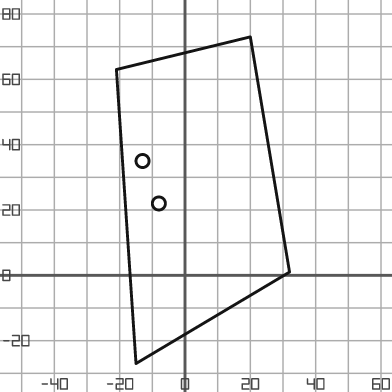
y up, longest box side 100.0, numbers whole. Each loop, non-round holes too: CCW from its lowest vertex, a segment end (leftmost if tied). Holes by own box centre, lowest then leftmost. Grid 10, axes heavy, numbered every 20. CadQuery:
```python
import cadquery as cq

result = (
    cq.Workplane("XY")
    .moveTo(-15.0, -27.0)
    .lineTo(32.0, 1.0)
    .lineTo(20.0, 73.0)
    .lineTo(-21.0, 63.0)
    .close()
    .moveTo(-8.0, 22.0)
    .circle(2.0)
    .moveTo(-13.0, 35.0)
    .circle(2.0)
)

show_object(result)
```